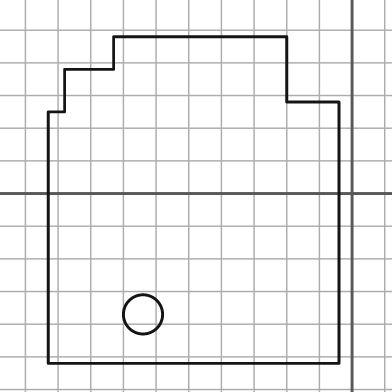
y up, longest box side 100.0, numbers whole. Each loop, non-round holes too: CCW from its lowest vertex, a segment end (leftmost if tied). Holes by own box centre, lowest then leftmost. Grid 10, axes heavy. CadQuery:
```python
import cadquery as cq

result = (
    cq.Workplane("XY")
    .moveTo(-93.0, -52.0)
    .lineTo(-4.0, -52.0)
    .lineTo(-4.0, 28.0)
    .lineTo(-20.0, 28.0)
    .lineTo(-20.0, 48.0)
    .lineTo(-73.0, 48.0)
    .lineTo(-73.0, 38.0)
    .lineTo(-88.0, 38.0)
    .lineTo(-88.0, 25.0)
    .lineTo(-93.0, 25.0)
    .close()
    .moveTo(-64.0, -37.0)
    .circle(6.0)
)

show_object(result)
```